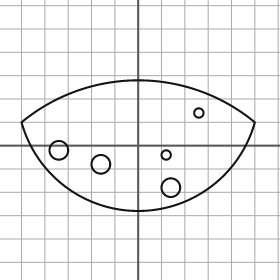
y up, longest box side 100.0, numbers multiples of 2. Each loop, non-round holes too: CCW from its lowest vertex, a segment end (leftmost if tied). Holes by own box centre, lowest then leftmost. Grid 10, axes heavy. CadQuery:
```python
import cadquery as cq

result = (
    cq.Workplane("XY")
    .moveTo(-50.0, 10.0)
    .threePointArc((0.0, -28.0), (50.0, 10.0))
    .threePointArc((0.0, 28.0), (-50.0, 10.0))
    .close()
    .moveTo(14.0, -18.0)
    .circle(4.0)
    .moveTo(-16.0, -8.0)
    .circle(4.0)
    .moveTo(12.0, -4.0)
    .circle(2.0)
    .moveTo(-34.0, -2.0)
    .circle(4.0)
    .moveTo(26.0, 14.0)
    .circle(2.0)
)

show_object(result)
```